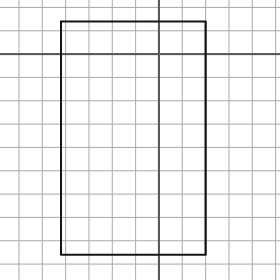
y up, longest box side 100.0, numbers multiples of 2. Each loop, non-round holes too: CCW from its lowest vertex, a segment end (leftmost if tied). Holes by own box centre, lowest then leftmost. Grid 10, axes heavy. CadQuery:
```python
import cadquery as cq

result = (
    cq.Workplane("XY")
    .moveTo(-42.0, -86.0)
    .lineTo(20.0, -86.0)
    .lineTo(20.0, 14.0)
    .lineTo(-42.0, 14.0)
    .close()
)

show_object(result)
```